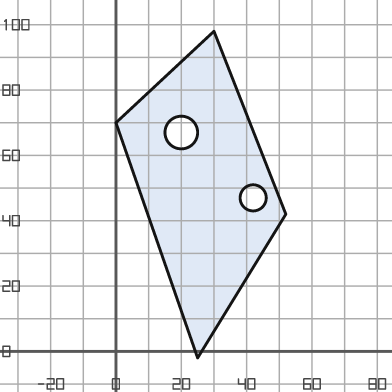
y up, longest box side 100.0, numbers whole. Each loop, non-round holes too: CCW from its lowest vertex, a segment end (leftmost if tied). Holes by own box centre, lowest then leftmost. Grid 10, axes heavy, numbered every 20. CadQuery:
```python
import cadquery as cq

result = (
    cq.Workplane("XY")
    .moveTo(25.0, -2.0)
    .lineTo(52.0, 42.0)
    .lineTo(30.0, 98.0)
    .lineTo(0.0, 70.0)
    .close()
    .moveTo(42.0, 47.0)
    .circle(4.0)
    .moveTo(20.0, 67.0)
    .circle(5.0)
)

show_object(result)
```